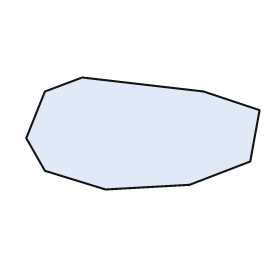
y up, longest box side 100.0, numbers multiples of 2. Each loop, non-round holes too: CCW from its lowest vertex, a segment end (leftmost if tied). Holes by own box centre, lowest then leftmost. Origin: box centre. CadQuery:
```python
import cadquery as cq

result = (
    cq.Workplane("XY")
    .moveTo(-16.0, -24.0)
    .lineTo(20.0, -22.0)
    .lineTo(46.0, -12.0)
    .lineTo(50.0, 10.0)
    .lineTo(26.0, 18.0)
    .lineTo(-26.0, 24.0)
    .lineTo(-42.0, 18.0)
    .lineTo(-50.0, -2.0)
    .lineTo(-42.0, -16.0)
    .close()
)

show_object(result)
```